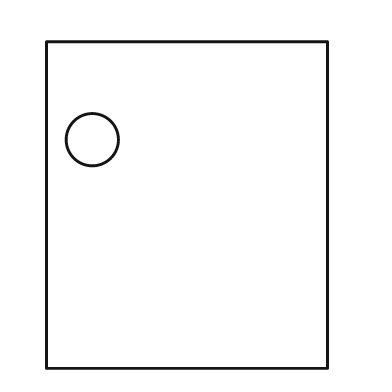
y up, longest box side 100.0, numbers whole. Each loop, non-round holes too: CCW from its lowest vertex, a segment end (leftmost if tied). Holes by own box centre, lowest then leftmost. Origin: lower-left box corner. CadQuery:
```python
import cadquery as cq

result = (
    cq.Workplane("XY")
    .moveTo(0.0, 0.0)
    .lineTo(86.0, 0.0)
    .lineTo(86.0, 100.0)
    .lineTo(0.0, 100.0)
    .close()
    .moveTo(14.0, 70.0)
    .circle(8.0)
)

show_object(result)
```